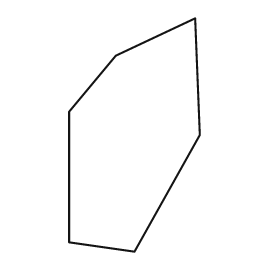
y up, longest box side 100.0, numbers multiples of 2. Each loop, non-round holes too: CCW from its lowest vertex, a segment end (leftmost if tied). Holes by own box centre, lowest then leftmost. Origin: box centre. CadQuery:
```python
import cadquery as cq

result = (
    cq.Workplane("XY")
    .moveTo(0.0, -50.0)
    .lineTo(28.0, 0.0)
    .lineTo(26.0, 50.0)
    .lineTo(-8.0, 34.0)
    .lineTo(-28.0, 10.0)
    .lineTo(-28.0, -46.0)
    .close()
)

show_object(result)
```